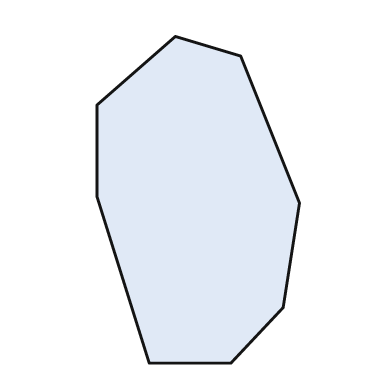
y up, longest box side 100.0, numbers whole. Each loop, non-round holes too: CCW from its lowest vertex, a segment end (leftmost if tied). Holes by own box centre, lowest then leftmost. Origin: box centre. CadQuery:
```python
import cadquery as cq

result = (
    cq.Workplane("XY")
    .moveTo(-15.0, -50.0)
    .lineTo(10.0, -50.0)
    .lineTo(26.0, -33.0)
    .lineTo(31.0, -1.0)
    .lineTo(13.0, 44.0)
    .lineTo(-7.0, 50.0)
    .lineTo(-31.0, 29.0)
    .lineTo(-31.0, 1.0)
    .close()
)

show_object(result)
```